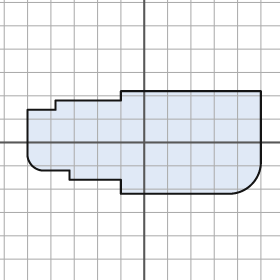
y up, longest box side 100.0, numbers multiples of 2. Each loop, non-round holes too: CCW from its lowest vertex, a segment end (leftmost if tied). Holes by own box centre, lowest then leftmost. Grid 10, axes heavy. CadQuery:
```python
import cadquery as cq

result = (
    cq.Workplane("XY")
    .moveTo(-10.0, -22.0)
    .lineTo(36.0, -22.0)
    .threePointArc((46.0, -18.0), (50.0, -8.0))
    .lineTo(50.0, 22.0)
    .lineTo(-10.0, 22.0)
    .lineTo(-10.0, 18.0)
    .lineTo(-38.0, 18.0)
    .lineTo(-38.0, 14.0)
    .lineTo(-50.0, 14.0)
    .lineTo(-50.0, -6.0)
    .threePointArc((-48.0, -10.0), (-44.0, -12.0))
    .lineTo(-32.0, -12.0)
    .lineTo(-32.0, -16.0)
    .lineTo(-10.0, -16.0)
    .close()
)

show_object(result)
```